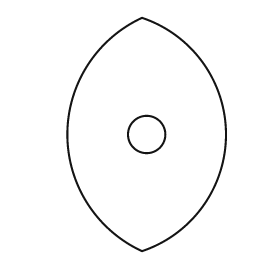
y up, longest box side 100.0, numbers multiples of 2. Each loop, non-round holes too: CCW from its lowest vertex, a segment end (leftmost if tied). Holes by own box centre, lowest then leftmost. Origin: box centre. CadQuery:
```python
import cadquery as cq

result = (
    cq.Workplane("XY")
    .moveTo(-2.0, -50.0)
    .threePointArc((34.0, 0.0), (-2.0, 50.0))
    .threePointArc((-34.0, 0.0), (-2.0, -50.0))
    .close()
    .moveTo(0.0, 0.0)
    .circle(8.0)
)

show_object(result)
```